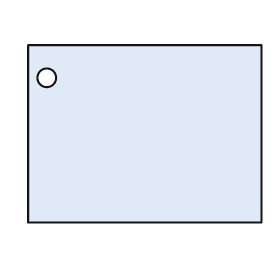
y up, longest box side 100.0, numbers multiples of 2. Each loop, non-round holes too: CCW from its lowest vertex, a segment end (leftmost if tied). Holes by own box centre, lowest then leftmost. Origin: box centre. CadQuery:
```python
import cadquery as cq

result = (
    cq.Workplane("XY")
    .moveTo(-50.0, -38.0)
    .lineTo(50.0, -38.0)
    .lineTo(50.0, 38.0)
    .lineTo(-50.0, 38.0)
    .close()
    .moveTo(-42.0, 24.0)
    .circle(4.0)
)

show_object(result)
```